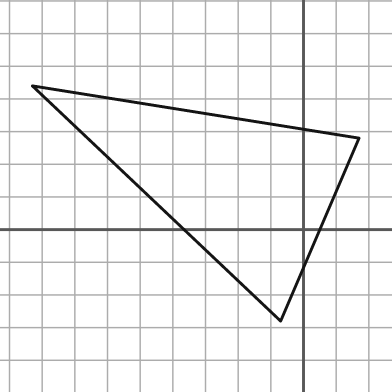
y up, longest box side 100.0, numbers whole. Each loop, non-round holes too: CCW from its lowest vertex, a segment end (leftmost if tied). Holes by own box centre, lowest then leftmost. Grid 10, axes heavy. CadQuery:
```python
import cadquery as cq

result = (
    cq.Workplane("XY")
    .moveTo(-7.0, -28.0)
    .lineTo(17.0, 28.0)
    .lineTo(-83.0, 44.0)
    .close()
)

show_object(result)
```